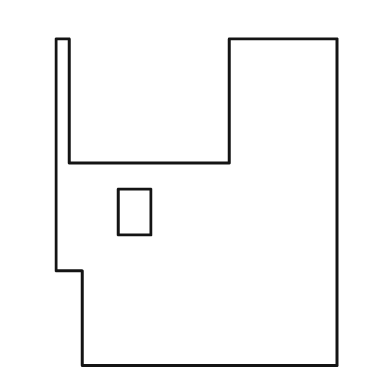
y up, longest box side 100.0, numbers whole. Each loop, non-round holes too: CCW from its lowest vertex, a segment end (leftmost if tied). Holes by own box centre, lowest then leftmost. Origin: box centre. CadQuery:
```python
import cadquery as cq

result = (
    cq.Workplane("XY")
    .moveTo(-35.0, -50.0)
    .lineTo(43.0, -50.0)
    .lineTo(43.0, 50.0)
    .lineTo(10.0, 50.0)
    .lineTo(10.0, 12.0)
    .lineTo(-39.0, 12.0)
    .lineTo(-39.0, 50.0)
    .lineTo(-43.0, 50.0)
    .lineTo(-43.0, -21.0)
    .lineTo(-35.0, -21.0)
    .close()
    .moveTo(-24.0, -10.0)
    .lineTo(-14.0, -10.0)
    .lineTo(-14.0, 4.0)
    .lineTo(-24.0, 4.0)
    .close()
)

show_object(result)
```